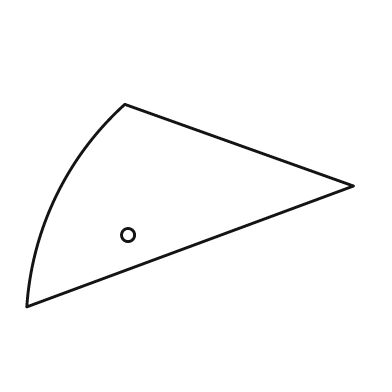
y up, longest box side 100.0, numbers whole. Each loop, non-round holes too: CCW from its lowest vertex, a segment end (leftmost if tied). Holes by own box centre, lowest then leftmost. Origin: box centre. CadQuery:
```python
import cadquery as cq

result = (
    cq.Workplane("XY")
    .moveTo(-50.0, -31.0)
    .lineTo(50.0, 6.0)
    .lineTo(-20.0, 31.0)
    .threePointArc((-41.0, 3.0), (-50.0, -31.0))
    .close()
    .moveTo(-19.0, -9.0)
    .circle(2.0)
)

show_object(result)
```